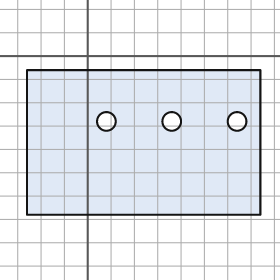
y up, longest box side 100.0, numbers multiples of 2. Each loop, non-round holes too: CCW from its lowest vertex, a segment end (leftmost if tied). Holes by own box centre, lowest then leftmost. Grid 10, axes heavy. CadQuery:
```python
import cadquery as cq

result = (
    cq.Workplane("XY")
    .moveTo(-26.0, -68.0)
    .lineTo(74.0, -68.0)
    .lineTo(74.0, -6.0)
    .lineTo(-26.0, -6.0)
    .close()
    .moveTo(8.0, -28.0)
    .circle(4.0)
    .moveTo(36.0, -28.0)
    .circle(4.0)
    .moveTo(64.0, -28.0)
    .circle(4.0)
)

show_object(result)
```